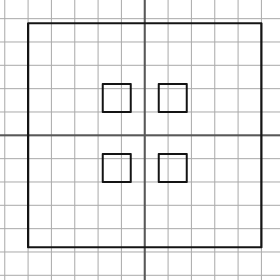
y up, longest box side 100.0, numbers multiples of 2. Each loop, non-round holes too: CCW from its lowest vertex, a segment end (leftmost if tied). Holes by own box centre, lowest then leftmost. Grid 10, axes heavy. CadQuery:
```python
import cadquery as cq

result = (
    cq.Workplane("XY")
    .moveTo(-50.0, -48.0)
    .lineTo(50.0, -48.0)
    .lineTo(50.0, 48.0)
    .lineTo(-50.0, 48.0)
    .close()
    .moveTo(-18.0, -20.0)
    .lineTo(-6.0, -20.0)
    .lineTo(-6.0, -8.0)
    .lineTo(-18.0, -8.0)
    .close()
    .moveTo(6.0, -20.0)
    .lineTo(18.0, -20.0)
    .lineTo(18.0, -8.0)
    .lineTo(6.0, -8.0)
    .close()
    .moveTo(-18.0, 10.0)
    .lineTo(-6.0, 10.0)
    .lineTo(-6.0, 22.0)
    .lineTo(-18.0, 22.0)
    .close()
    .moveTo(6.0, 10.0)
    .lineTo(18.0, 10.0)
    .lineTo(18.0, 22.0)
    .lineTo(6.0, 22.0)
    .close()
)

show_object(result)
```